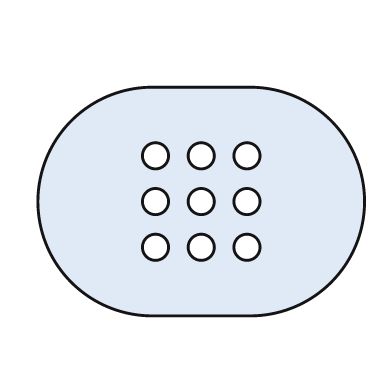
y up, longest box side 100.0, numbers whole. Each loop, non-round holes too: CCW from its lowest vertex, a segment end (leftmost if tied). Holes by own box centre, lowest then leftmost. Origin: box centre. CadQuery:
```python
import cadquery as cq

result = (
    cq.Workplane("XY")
    .moveTo(-15.0, -35.0)
    .lineTo(15.0, -35.0)
    .threePointArc((50.0, 0.0), (15.0, 35.0))
    .lineTo(-15.0, 35.0)
    .threePointArc((-50.0, 0.0), (-15.0, -35.0))
    .close()
    .moveTo(-14.0, -14.0)
    .circle(4.0)
    .moveTo(0.0, -14.0)
    .circle(4.0)
    .moveTo(14.0, -14.0)
    .circle(4.0)
    .moveTo(-14.0, 0.0)
    .circle(4.0)
    .moveTo(0.0, 0.0)
    .circle(4.0)
    .moveTo(14.0, 0.0)
    .circle(4.0)
    .moveTo(-14.0, 14.0)
    .circle(4.0)
    .moveTo(0.0, 14.0)
    .circle(4.0)
    .moveTo(14.0, 14.0)
    .circle(4.0)
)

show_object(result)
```